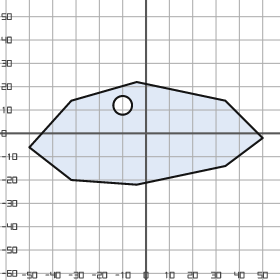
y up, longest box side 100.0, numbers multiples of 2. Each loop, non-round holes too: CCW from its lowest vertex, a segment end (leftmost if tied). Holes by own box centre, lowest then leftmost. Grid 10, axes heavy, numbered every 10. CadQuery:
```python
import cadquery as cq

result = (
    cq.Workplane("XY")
    .moveTo(-4.0, -22.0)
    .lineTo(34.0, -14.0)
    .lineTo(50.0, -2.0)
    .lineTo(34.0, 14.0)
    .lineTo(-4.0, 22.0)
    .lineTo(-32.0, 14.0)
    .lineTo(-50.0, -6.0)
    .lineTo(-32.0, -20.0)
    .close()
    .moveTo(-10.0, 12.0)
    .circle(4.0)
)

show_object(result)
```